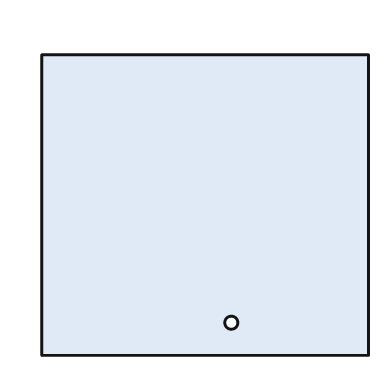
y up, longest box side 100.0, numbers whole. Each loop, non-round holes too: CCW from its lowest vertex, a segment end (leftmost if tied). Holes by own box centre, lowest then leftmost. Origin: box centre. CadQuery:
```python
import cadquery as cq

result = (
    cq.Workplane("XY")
    .moveTo(-50.0, -46.0)
    .lineTo(50.0, -46.0)
    .lineTo(50.0, 46.0)
    .lineTo(-50.0, 46.0)
    .close()
    .moveTo(8.0, -36.0)
    .circle(2.0)
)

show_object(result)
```